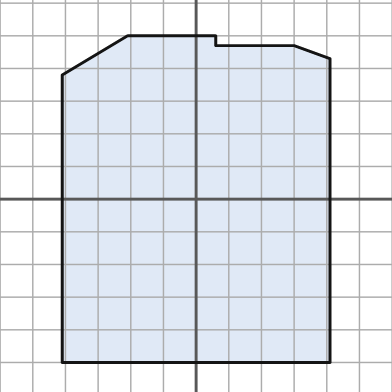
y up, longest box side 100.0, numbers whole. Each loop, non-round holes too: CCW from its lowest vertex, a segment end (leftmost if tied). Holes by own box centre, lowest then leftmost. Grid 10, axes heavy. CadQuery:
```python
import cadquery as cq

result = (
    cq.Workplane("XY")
    .moveTo(-41.0, -50.0)
    .lineTo(41.0, -50.0)
    .lineTo(41.0, 43.0)
    .lineTo(30.0, 47.0)
    .lineTo(6.0, 47.0)
    .lineTo(6.0, 50.0)
    .lineTo(-21.0, 50.0)
    .lineTo(-41.0, 38.0)
    .close()
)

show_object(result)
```